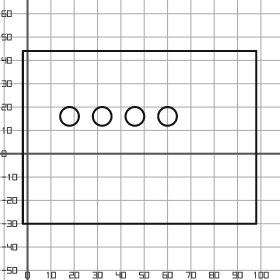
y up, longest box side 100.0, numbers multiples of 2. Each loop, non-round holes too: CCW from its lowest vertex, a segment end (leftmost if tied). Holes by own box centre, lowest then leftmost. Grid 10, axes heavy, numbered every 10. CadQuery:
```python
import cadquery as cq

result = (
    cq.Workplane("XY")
    .moveTo(-2.0, -30.0)
    .lineTo(98.0, -30.0)
    .lineTo(98.0, 44.0)
    .lineTo(-2.0, 44.0)
    .close()
    .moveTo(18.0, 16.0)
    .circle(4.0)
    .moveTo(32.0, 16.0)
    .circle(4.0)
    .moveTo(46.0, 16.0)
    .circle(4.0)
    .moveTo(60.0, 16.0)
    .circle(4.0)
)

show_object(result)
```